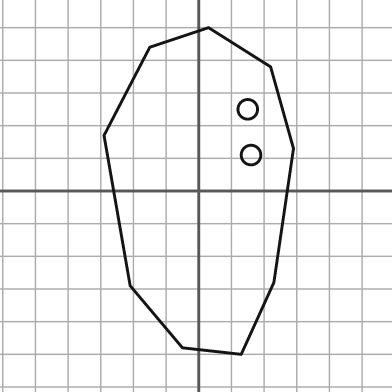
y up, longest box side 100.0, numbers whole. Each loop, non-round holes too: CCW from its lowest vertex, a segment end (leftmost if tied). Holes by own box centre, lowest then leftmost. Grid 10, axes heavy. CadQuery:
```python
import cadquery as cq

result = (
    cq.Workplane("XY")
    .moveTo(13.0, -50.0)
    .lineTo(23.0, -28.0)
    .lineTo(29.0, 13.0)
    .lineTo(22.0, 38.0)
    .lineTo(3.0, 50.0)
    .lineTo(-15.0, 44.0)
    .lineTo(-29.0, 17.0)
    .lineTo(-21.0, -29.0)
    .lineTo(-5.0, -48.0)
    .close()
    .moveTo(16.0, 11.0)
    .circle(3.0)
    .moveTo(15.0, 25.0)
    .circle(3.0)
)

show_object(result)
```